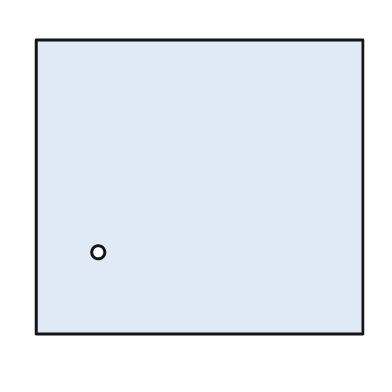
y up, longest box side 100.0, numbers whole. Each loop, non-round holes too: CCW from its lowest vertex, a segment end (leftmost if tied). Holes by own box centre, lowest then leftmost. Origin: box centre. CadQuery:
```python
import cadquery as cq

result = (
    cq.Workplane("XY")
    .moveTo(-50.0, -45.0)
    .lineTo(50.0, -45.0)
    .lineTo(50.0, 45.0)
    .lineTo(-50.0, 45.0)
    .close()
    .moveTo(-31.0, -20.0)
    .circle(2.0)
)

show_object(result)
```